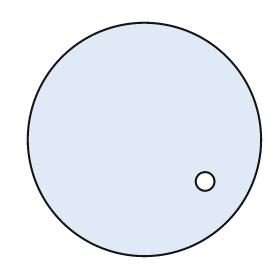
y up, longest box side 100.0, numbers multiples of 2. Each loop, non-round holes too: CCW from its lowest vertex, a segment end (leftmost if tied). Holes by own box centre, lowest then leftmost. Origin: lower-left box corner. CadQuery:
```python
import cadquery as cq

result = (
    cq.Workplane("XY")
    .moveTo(50.0, 50.0)
    .circle(50.0)
    .moveTo(76.0, 32.0)
    .circle(4.0)
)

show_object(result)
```